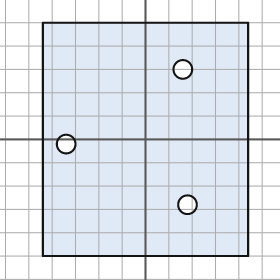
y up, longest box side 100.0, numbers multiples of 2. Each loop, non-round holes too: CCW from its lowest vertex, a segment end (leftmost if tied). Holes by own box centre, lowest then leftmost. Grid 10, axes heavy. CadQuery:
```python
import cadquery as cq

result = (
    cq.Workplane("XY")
    .moveTo(-44.0, -50.0)
    .lineTo(44.0, -50.0)
    .lineTo(44.0, 50.0)
    .lineTo(-44.0, 50.0)
    .close()
    .moveTo(18.0, -28.0)
    .circle(4.0)
    .moveTo(-34.0, -2.0)
    .circle(4.0)
    .moveTo(16.0, 30.0)
    .circle(4.0)
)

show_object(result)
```